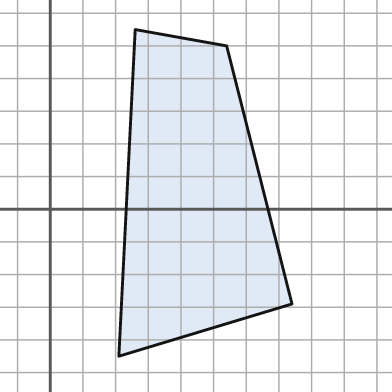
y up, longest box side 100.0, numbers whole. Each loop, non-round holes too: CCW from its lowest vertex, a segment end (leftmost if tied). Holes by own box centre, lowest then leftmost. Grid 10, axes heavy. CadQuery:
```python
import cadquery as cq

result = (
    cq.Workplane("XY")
    .moveTo(21.0, -45.0)
    .lineTo(74.0, -29.0)
    .lineTo(54.0, 50.0)
    .lineTo(26.0, 55.0)
    .close()
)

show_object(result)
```